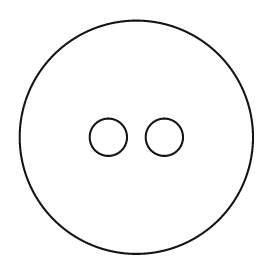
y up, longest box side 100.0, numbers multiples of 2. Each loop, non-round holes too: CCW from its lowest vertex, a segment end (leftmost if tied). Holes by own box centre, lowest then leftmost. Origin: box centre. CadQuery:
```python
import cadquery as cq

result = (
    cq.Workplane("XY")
    .moveTo(0.0, 0.0)
    .circle(50.0)
    .moveTo(-12.0, 0.0)
    .circle(8.0)
    .moveTo(12.0, 0.0)
    .circle(8.0)
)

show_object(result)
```